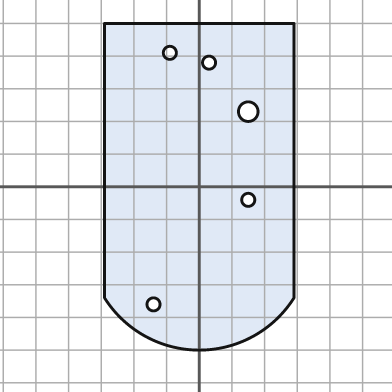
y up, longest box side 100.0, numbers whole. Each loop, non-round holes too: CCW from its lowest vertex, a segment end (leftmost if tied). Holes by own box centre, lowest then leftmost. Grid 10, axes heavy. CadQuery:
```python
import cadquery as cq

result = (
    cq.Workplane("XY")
    .moveTo(-29.0, -34.0)
    .threePointArc((0.0, -50.0), (29.0, -34.0))
    .lineTo(29.0, 50.0)
    .lineTo(-29.0, 50.0)
    .close()
    .moveTo(-14.0, -36.0)
    .circle(2.0)
    .moveTo(15.0, -4.0)
    .circle(2.0)
    .moveTo(15.0, 23.0)
    .circle(3.0)
    .moveTo(3.0, 38.0)
    .circle(2.0)
    .moveTo(-9.0, 41.0)
    .circle(2.0)
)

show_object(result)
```